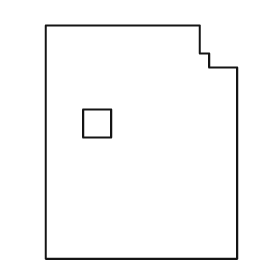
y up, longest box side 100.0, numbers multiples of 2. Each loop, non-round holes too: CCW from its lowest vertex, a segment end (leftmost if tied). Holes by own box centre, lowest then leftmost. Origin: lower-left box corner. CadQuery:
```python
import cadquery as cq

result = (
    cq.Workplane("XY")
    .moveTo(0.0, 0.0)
    .lineTo(82.0, 0.0)
    .lineTo(82.0, 82.0)
    .lineTo(70.0, 82.0)
    .lineTo(70.0, 88.0)
    .lineTo(66.0, 88.0)
    .lineTo(66.0, 100.0)
    .lineTo(0.0, 100.0)
    .close()
    .moveTo(16.0, 52.0)
    .lineTo(28.0, 52.0)
    .lineTo(28.0, 64.0)
    .lineTo(16.0, 64.0)
    .close()
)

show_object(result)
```